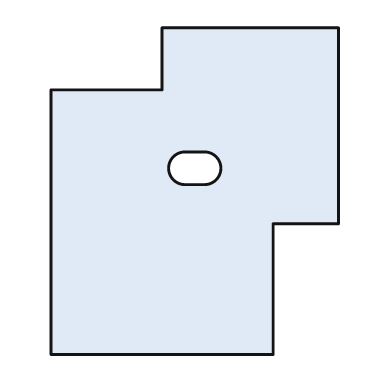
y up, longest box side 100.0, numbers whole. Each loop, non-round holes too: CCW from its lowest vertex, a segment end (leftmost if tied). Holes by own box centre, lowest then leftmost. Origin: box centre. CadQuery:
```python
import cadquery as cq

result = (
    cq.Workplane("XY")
    .moveTo(-44.0, -50.0)
    .lineTo(24.0, -50.0)
    .lineTo(24.0, -10.0)
    .lineTo(44.0, -10.0)
    .lineTo(44.0, 50.0)
    .lineTo(-10.0, 50.0)
    .lineTo(-10.0, 31.0)
    .lineTo(-44.0, 31.0)
    .close()
    .moveTo(-3.0, 2.0)
    .lineTo(3.0, 2.0)
    .threePointArc((8.0, 7.0), (3.0, 12.0))
    .lineTo(-3.0, 12.0)
    .threePointArc((-8.0, 7.0), (-3.0, 2.0))
    .close()
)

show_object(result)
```